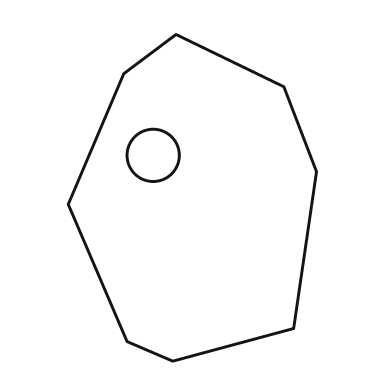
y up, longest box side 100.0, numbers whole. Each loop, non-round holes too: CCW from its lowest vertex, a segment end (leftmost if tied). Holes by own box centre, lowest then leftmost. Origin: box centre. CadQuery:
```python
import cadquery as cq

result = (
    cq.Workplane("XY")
    .moveTo(-6.0, -50.0)
    .lineTo(31.0, -40.0)
    .lineTo(38.0, 8.0)
    .lineTo(28.0, 34.0)
    .lineTo(-5.0, 50.0)
    .lineTo(-21.0, 38.0)
    .lineTo(-38.0, -2.0)
    .lineTo(-20.0, -44.0)
    .close()
    .moveTo(-12.0, 13.0)
    .circle(8.0)
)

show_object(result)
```